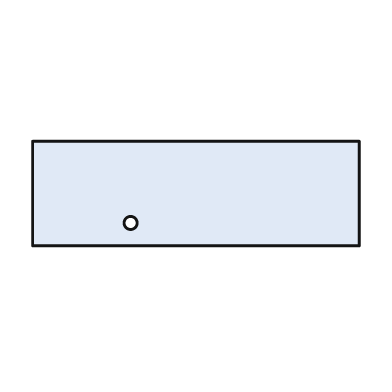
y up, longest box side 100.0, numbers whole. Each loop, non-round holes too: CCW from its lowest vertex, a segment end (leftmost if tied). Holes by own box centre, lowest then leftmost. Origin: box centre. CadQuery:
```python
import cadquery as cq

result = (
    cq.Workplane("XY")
    .moveTo(-50.0, -16.0)
    .lineTo(50.0, -16.0)
    .lineTo(50.0, 16.0)
    .lineTo(-50.0, 16.0)
    .close()
    .moveTo(-20.0, -9.0)
    .circle(2.0)
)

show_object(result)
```